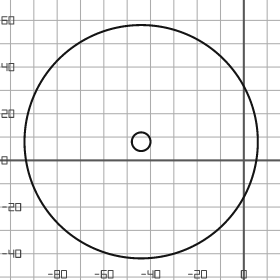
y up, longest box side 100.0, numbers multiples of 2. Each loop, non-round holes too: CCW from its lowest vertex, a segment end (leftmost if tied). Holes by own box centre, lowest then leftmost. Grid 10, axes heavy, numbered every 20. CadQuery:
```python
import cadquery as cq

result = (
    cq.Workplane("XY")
    .moveTo(-44.0, 8.0)
    .circle(50.0)
    .moveTo(-44.0, 8.0)
    .circle(4.0)
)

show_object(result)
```